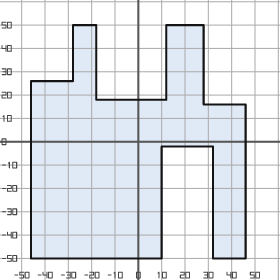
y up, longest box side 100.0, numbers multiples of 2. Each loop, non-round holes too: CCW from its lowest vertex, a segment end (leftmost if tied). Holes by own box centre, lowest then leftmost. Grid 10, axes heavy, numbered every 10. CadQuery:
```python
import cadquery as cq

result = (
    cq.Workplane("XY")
    .moveTo(-46.0, -50.0)
    .lineTo(10.0, -50.0)
    .lineTo(10.0, -2.0)
    .lineTo(32.0, -2.0)
    .lineTo(32.0, -50.0)
    .lineTo(46.0, -50.0)
    .lineTo(46.0, 16.0)
    .lineTo(28.0, 16.0)
    .lineTo(28.0, 50.0)
    .lineTo(12.0, 50.0)
    .lineTo(12.0, 18.0)
    .lineTo(-18.0, 18.0)
    .lineTo(-18.0, 50.0)
    .lineTo(-28.0, 50.0)
    .lineTo(-28.0, 26.0)
    .lineTo(-46.0, 26.0)
    .close()
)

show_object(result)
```